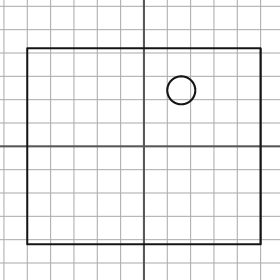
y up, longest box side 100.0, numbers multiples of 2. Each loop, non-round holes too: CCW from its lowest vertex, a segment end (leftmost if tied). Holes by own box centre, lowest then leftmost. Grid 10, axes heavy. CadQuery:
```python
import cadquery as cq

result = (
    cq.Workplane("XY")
    .moveTo(-50.0, -42.0)
    .lineTo(50.0, -42.0)
    .lineTo(50.0, 42.0)
    .lineTo(-50.0, 42.0)
    .close()
    .moveTo(16.0, 24.0)
    .circle(6.0)
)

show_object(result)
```